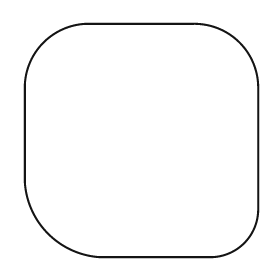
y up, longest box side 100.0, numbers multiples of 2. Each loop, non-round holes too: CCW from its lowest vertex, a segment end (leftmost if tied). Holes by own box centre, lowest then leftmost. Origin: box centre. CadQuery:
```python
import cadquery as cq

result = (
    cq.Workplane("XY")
    .moveTo(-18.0, -50.0)
    .lineTo(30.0, -50.0)
    .threePointArc((44.0, -44.0), (50.0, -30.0))
    .lineTo(50.0, 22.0)
    .threePointArc((42.0, 42.0), (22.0, 50.0))
    .lineTo(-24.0, 50.0)
    .threePointArc((-42.0, 42.0), (-50.0, 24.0))
    .lineTo(-50.0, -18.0)
    .threePointArc((-40.0, -40.0), (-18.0, -50.0))
    .close()
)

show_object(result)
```